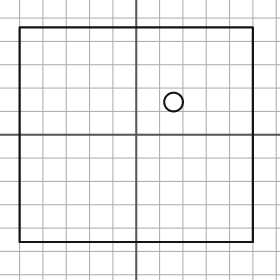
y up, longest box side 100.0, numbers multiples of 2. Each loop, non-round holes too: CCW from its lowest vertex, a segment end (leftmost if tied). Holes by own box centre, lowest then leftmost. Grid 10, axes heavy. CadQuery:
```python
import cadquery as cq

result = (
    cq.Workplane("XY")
    .moveTo(-50.0, -46.0)
    .lineTo(50.0, -46.0)
    .lineTo(50.0, 46.0)
    .lineTo(-50.0, 46.0)
    .close()
    .moveTo(16.0, 14.0)
    .circle(4.0)
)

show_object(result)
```